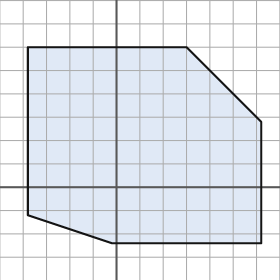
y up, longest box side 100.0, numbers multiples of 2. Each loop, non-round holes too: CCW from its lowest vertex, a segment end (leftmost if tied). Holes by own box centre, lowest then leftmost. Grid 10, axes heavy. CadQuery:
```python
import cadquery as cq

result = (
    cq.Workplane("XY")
    .moveTo(-2.0, -24.0)
    .lineTo(62.0, -24.0)
    .lineTo(62.0, 28.0)
    .lineTo(30.0, 60.0)
    .lineTo(-38.0, 60.0)
    .lineTo(-38.0, -12.0)
    .close()
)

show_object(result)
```